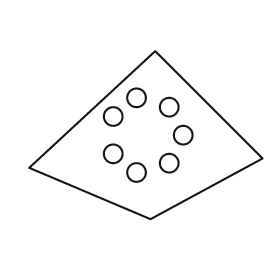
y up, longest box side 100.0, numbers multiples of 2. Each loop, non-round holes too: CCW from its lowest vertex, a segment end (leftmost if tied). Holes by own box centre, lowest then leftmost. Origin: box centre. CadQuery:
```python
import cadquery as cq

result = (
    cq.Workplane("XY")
    .moveTo(2.0, -36.0)
    .lineTo(50.0, -10.0)
    .lineTo(4.0, 36.0)
    .lineTo(-50.0, -14.0)
    .close()
    .moveTo(-4.0, -16.0)
    .circle(4.0)
    .moveTo(10.0, -12.0)
    .circle(4.0)
    .moveTo(-14.0, -8.0)
    .circle(4.0)
    .moveTo(16.0, 0.0)
    .circle(4.0)
    .moveTo(-14.0, 8.0)
    .circle(4.0)
    .moveTo(10.0, 12.0)
    .circle(4.0)
    .moveTo(-4.0, 16.0)
    .circle(4.0)
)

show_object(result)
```